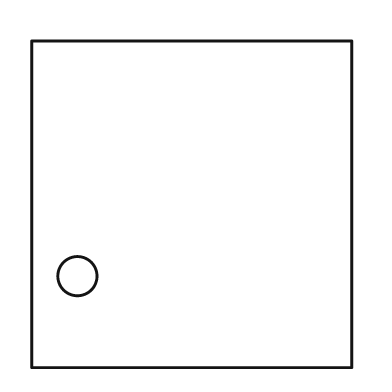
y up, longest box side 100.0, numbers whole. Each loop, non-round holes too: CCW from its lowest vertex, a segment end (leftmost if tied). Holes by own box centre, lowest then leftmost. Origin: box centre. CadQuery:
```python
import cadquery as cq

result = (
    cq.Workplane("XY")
    .moveTo(-49.0, -50.0)
    .lineTo(49.0, -50.0)
    .lineTo(49.0, 50.0)
    .lineTo(-49.0, 50.0)
    .close()
    .moveTo(-35.0, -22.0)
    .circle(6.0)
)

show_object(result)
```